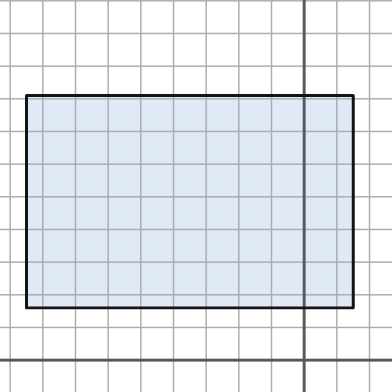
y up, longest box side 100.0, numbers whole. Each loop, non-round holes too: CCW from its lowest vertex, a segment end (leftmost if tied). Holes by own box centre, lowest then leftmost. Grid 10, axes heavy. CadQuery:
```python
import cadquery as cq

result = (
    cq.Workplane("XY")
    .moveTo(-85.0, 16.0)
    .lineTo(15.0, 16.0)
    .lineTo(15.0, 81.0)
    .lineTo(-85.0, 81.0)
    .close()
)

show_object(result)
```